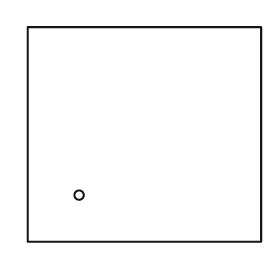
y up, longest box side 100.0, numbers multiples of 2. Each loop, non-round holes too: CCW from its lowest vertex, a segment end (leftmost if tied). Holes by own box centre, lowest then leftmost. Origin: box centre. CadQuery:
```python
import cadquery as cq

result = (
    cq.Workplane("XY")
    .moveTo(-50.0, -46.0)
    .lineTo(50.0, -46.0)
    .lineTo(50.0, 46.0)
    .lineTo(-50.0, 46.0)
    .close()
    .moveTo(-28.0, -26.0)
    .circle(2.0)
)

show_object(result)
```